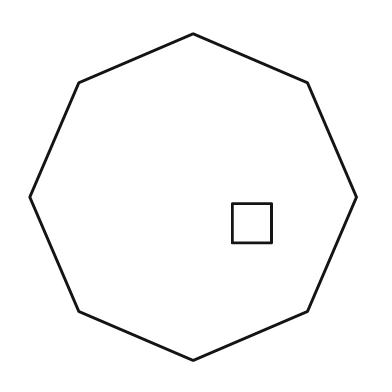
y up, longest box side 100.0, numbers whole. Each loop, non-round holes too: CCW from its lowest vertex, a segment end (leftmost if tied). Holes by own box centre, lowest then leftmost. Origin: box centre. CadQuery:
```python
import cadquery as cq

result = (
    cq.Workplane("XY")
    .moveTo(0.0, -50.0)
    .lineTo(35.0, -35.0)
    .lineTo(50.0, 0.0)
    .lineTo(35.0, 35.0)
    .lineTo(0.0, 50.0)
    .lineTo(-35.0, 35.0)
    .lineTo(-50.0, 0.0)
    .lineTo(-35.0, -35.0)
    .close()
    .moveTo(12.0, -14.0)
    .lineTo(24.0, -14.0)
    .lineTo(24.0, -2.0)
    .lineTo(12.0, -2.0)
    .close()
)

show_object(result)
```